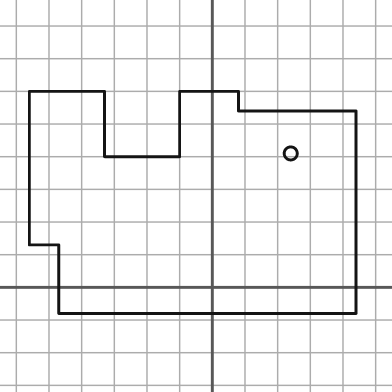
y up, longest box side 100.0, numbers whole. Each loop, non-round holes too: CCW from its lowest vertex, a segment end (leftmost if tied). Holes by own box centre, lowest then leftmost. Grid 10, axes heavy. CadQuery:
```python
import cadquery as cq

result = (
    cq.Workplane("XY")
    .moveTo(-47.0, -8.0)
    .lineTo(44.0, -8.0)
    .lineTo(44.0, 54.0)
    .lineTo(8.0, 54.0)
    .lineTo(8.0, 60.0)
    .lineTo(-10.0, 60.0)
    .lineTo(-10.0, 40.0)
    .lineTo(-33.0, 40.0)
    .lineTo(-33.0, 60.0)
    .lineTo(-56.0, 60.0)
    .lineTo(-56.0, 13.0)
    .lineTo(-47.0, 13.0)
    .close()
    .moveTo(24.0, 41.0)
    .circle(2.0)
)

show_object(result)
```